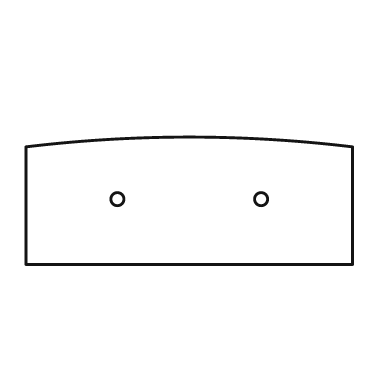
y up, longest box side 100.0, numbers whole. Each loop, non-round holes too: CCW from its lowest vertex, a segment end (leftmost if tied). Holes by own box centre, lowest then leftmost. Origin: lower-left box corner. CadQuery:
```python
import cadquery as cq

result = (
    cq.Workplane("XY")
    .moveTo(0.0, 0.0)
    .lineTo(100.0, 0.0)
    .lineTo(100.0, 36.0)
    .threePointArc((50.0, 39.0), (0.0, 36.0))
    .close()
    .moveTo(28.0, 20.0)
    .circle(2.0)
    .moveTo(72.0, 20.0)
    .circle(2.0)
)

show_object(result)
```